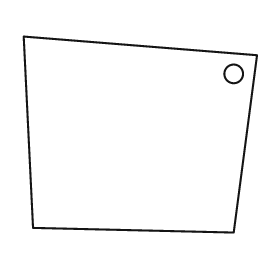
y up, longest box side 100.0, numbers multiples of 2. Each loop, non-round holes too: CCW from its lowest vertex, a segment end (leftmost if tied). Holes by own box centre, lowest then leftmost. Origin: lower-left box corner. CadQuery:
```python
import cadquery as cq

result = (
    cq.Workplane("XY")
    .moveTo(90.0, 0.0)
    .lineTo(100.0, 76.0)
    .lineTo(0.0, 84.0)
    .lineTo(4.0, 2.0)
    .close()
    .moveTo(90.0, 68.0)
    .circle(4.0)
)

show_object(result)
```